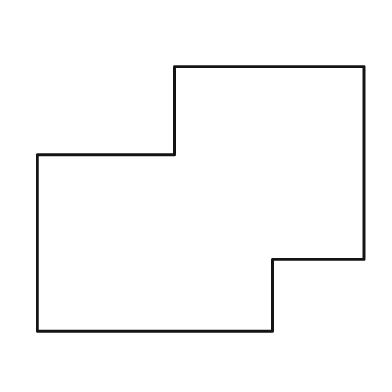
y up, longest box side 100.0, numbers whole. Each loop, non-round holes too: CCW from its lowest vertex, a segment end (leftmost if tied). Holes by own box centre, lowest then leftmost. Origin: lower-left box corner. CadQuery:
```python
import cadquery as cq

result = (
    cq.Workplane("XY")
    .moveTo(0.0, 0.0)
    .lineTo(72.0, 0.0)
    .lineTo(72.0, 22.0)
    .lineTo(100.0, 22.0)
    .lineTo(100.0, 81.0)
    .lineTo(42.0, 81.0)
    .lineTo(42.0, 54.0)
    .lineTo(0.0, 54.0)
    .close()
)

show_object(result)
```